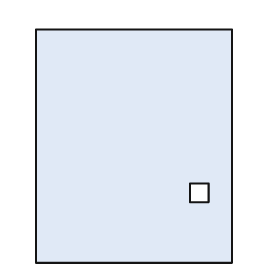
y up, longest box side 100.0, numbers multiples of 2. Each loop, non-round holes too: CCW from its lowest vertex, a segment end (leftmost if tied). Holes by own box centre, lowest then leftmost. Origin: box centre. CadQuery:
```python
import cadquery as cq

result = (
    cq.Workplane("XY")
    .moveTo(-42.0, -50.0)
    .lineTo(42.0, -50.0)
    .lineTo(42.0, 50.0)
    .lineTo(-42.0, 50.0)
    .close()
    .moveTo(24.0, -24.0)
    .lineTo(32.0, -24.0)
    .lineTo(32.0, -16.0)
    .lineTo(24.0, -16.0)
    .close()
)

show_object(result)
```